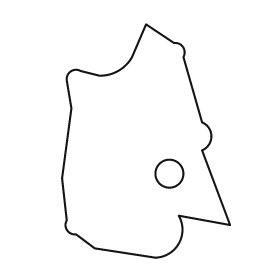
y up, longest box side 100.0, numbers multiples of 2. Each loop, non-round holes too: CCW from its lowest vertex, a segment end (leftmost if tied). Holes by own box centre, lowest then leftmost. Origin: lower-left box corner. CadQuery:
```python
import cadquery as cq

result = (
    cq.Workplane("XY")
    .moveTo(40.0, 0.0)
    .threePointArc((50.0, 6.0), (50.0, 18.0))
    .lineTo(72.0, 14.0)
    .lineTo(60.0, 46.0)
    .threePointArc((64.0, 52.0), (60.0, 58.0))
    .lineTo(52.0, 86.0)
    .threePointArc((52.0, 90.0), (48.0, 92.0))
    .lineTo(36.0, 100.0)
    .lineTo(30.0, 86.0)
    .threePointArc((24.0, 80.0), (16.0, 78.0))
    .lineTo(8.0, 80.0)
    .threePointArc((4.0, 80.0), (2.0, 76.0))
    .lineTo(4.0, 64.0)
    .lineTo(0.0, 34.0)
    .lineTo(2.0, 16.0)
    .threePointArc((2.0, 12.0), (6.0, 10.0))
    .lineTo(14.0, 4.0)
    .close()
    .moveTo(46.0, 36.0)
    .circle(6.0)
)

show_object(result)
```